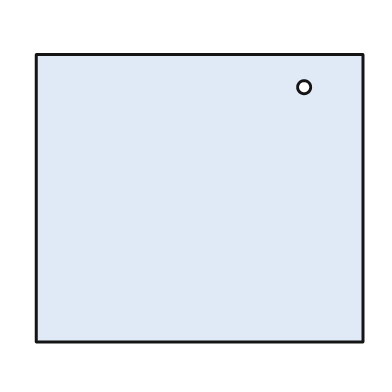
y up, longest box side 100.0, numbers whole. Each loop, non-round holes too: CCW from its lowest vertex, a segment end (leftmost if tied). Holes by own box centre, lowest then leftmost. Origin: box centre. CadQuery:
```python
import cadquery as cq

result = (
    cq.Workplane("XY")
    .moveTo(-50.0, -44.0)
    .lineTo(50.0, -44.0)
    .lineTo(50.0, 44.0)
    .lineTo(-50.0, 44.0)
    .close()
    .moveTo(32.0, 34.0)
    .circle(2.0)
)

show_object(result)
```